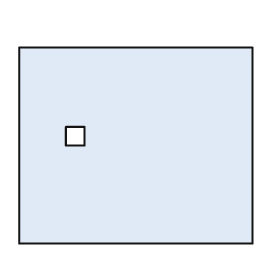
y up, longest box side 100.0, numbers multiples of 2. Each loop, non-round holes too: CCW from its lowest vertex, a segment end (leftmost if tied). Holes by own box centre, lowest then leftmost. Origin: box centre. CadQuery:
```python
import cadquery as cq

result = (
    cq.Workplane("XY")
    .moveTo(-50.0, -42.0)
    .lineTo(50.0, -42.0)
    .lineTo(50.0, 42.0)
    .lineTo(-50.0, 42.0)
    .close()
    .moveTo(-30.0, 0.0)
    .lineTo(-22.0, 0.0)
    .lineTo(-22.0, 8.0)
    .lineTo(-30.0, 8.0)
    .close()
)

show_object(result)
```